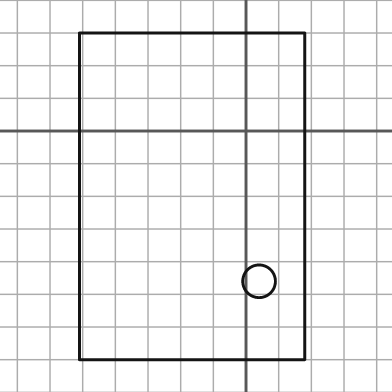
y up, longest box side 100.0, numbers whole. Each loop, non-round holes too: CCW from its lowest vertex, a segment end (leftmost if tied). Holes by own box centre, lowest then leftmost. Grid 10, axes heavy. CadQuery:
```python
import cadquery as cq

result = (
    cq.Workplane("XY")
    .moveTo(-51.0, -70.0)
    .lineTo(18.0, -70.0)
    .lineTo(18.0, 30.0)
    .lineTo(-51.0, 30.0)
    .close()
    .moveTo(4.0, -46.0)
    .circle(5.0)
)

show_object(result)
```